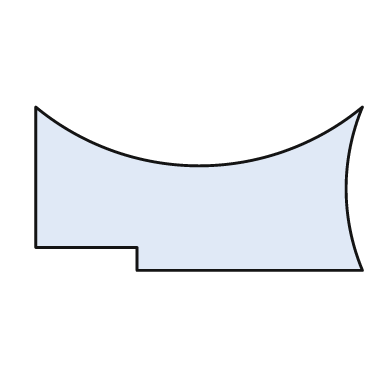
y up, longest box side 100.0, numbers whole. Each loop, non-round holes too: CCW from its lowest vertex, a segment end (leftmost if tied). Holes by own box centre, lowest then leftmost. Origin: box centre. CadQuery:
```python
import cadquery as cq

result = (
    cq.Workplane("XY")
    .moveTo(-19.0, -25.0)
    .lineTo(50.0, -25.0)
    .threePointArc((45.0, 0.0), (50.0, 25.0))
    .threePointArc((0.0, 7.0), (-50.0, 25.0))
    .lineTo(-50.0, -18.0)
    .lineTo(-19.0, -18.0)
    .close()
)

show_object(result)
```